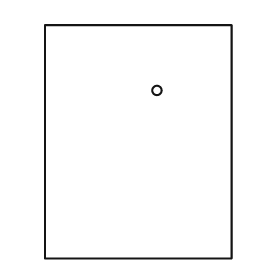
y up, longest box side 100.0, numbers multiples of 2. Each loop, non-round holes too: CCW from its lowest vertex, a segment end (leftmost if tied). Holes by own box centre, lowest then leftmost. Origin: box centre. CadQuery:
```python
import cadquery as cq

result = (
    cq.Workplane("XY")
    .moveTo(-40.0, -50.0)
    .lineTo(40.0, -50.0)
    .lineTo(40.0, 50.0)
    .lineTo(-40.0, 50.0)
    .close()
    .moveTo(8.0, 22.0)
    .circle(2.0)
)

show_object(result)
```